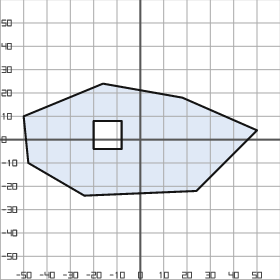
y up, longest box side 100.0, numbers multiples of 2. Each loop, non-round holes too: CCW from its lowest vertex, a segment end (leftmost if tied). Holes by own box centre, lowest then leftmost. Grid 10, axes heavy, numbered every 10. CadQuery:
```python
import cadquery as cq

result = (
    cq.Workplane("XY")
    .moveTo(-24.0, -24.0)
    .lineTo(24.0, -22.0)
    .lineTo(50.0, 4.0)
    .lineTo(18.0, 18.0)
    .lineTo(-16.0, 24.0)
    .lineTo(-50.0, 10.0)
    .lineTo(-48.0, -10.0)
    .close()
    .moveTo(-20.0, -4.0)
    .lineTo(-8.0, -4.0)
    .lineTo(-8.0, 8.0)
    .lineTo(-20.0, 8.0)
    .close()
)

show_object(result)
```